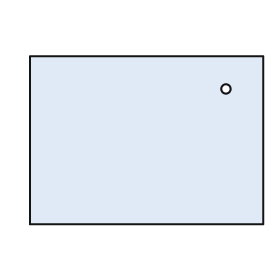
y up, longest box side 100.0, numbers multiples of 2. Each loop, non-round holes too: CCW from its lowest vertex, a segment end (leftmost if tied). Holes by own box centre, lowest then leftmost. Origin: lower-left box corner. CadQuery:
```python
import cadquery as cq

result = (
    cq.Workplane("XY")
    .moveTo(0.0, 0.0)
    .lineTo(100.0, 0.0)
    .lineTo(100.0, 72.0)
    .lineTo(0.0, 72.0)
    .close()
    .moveTo(84.0, 58.0)
    .circle(2.0)
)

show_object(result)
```